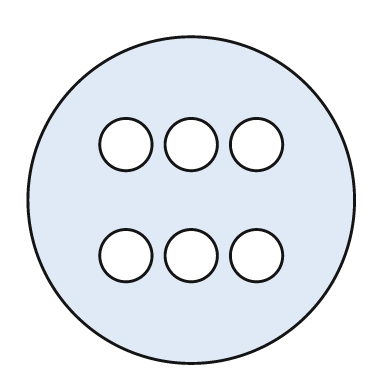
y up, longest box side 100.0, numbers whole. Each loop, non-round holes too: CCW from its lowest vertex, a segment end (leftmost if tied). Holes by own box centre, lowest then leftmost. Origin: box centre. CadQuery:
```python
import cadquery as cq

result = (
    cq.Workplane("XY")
    .moveTo(0.0, 0.0)
    .circle(50.0)
    .moveTo(-20.0, -17.0)
    .circle(8.0)
    .moveTo(0.0, -17.0)
    .circle(8.0)
    .moveTo(20.0, -17.0)
    .circle(8.0)
    .moveTo(-20.0, 17.0)
    .circle(8.0)
    .moveTo(0.0, 17.0)
    .circle(8.0)
    .moveTo(20.0, 17.0)
    .circle(8.0)
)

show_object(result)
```